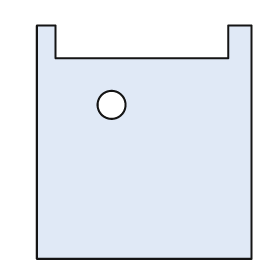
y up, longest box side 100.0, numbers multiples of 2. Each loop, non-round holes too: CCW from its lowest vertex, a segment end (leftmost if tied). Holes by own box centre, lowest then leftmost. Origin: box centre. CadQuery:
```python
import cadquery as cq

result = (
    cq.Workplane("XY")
    .moveTo(-46.0, -50.0)
    .lineTo(46.0, -50.0)
    .lineTo(46.0, 50.0)
    .lineTo(36.0, 50.0)
    .lineTo(36.0, 36.0)
    .lineTo(-38.0, 36.0)
    .lineTo(-38.0, 50.0)
    .lineTo(-46.0, 50.0)
    .close()
    .moveTo(-14.0, 16.0)
    .circle(6.0)
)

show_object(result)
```